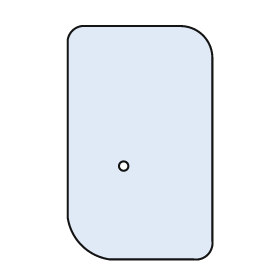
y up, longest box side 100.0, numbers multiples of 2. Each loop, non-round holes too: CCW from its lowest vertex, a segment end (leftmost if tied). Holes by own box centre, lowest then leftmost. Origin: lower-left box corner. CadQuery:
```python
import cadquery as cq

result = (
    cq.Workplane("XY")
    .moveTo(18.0, 0.0)
    .lineTo(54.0, 0.0)
    .threePointArc((60.0, 2.0), (62.0, 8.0))
    .lineTo(62.0, 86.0)
    .threePointArc((58.0, 96.0), (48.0, 100.0))
    .lineTo(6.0, 100.0)
    .threePointArc((2.0, 98.0), (0.0, 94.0))
    .lineTo(0.0, 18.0)
    .threePointArc((6.0, 6.0), (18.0, 0.0))
    .close()
    .moveTo(24.0, 40.0)
    .circle(2.0)
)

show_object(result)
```